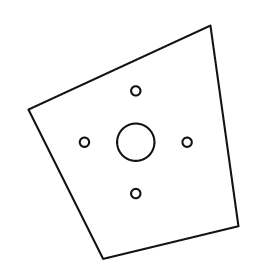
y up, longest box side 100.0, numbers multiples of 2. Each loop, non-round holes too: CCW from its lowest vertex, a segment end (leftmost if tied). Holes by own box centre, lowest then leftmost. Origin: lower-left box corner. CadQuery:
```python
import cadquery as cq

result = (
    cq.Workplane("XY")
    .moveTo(32.0, 0.0)
    .lineTo(90.0, 14.0)
    .lineTo(78.0, 100.0)
    .lineTo(0.0, 64.0)
    .close()
    .moveTo(46.0, 28.0)
    .circle(2.0)
    .moveTo(24.0, 50.0)
    .circle(2.0)
    .moveTo(46.0, 50.0)
    .circle(8.0)
    .moveTo(68.0, 50.0)
    .circle(2.0)
    .moveTo(46.0, 72.0)
    .circle(2.0)
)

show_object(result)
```